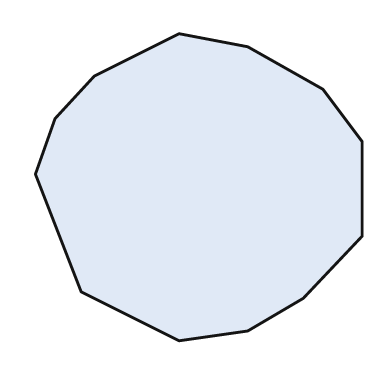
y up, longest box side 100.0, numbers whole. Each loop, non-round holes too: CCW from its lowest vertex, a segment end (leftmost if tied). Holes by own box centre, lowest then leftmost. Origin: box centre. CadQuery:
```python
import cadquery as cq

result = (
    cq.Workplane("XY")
    .moveTo(-6.0, -47.0)
    .lineTo(15.0, -44.0)
    .lineTo(32.0, -34.0)
    .lineTo(50.0, -15.0)
    .lineTo(50.0, 14.0)
    .lineTo(38.0, 30.0)
    .lineTo(15.0, 43.0)
    .lineTo(-6.0, 47.0)
    .lineTo(-32.0, 34.0)
    .lineTo(-44.0, 21.0)
    .lineTo(-50.0, 4.0)
    .lineTo(-36.0, -32.0)
    .close()
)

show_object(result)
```